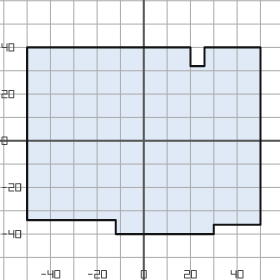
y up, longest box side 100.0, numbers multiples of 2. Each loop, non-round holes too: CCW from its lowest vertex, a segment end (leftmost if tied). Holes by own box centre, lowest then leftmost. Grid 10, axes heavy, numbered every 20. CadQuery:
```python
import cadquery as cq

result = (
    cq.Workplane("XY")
    .moveTo(-12.0, -40.0)
    .lineTo(30.0, -40.0)
    .lineTo(30.0, -36.0)
    .lineTo(50.0, -36.0)
    .lineTo(50.0, 40.0)
    .lineTo(26.0, 40.0)
    .lineTo(26.0, 32.0)
    .lineTo(20.0, 32.0)
    .lineTo(20.0, 40.0)
    .lineTo(-50.0, 40.0)
    .lineTo(-50.0, -34.0)
    .lineTo(-12.0, -34.0)
    .close()
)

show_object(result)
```